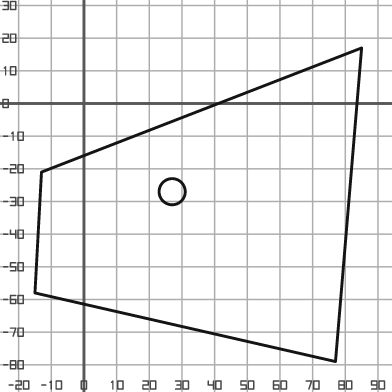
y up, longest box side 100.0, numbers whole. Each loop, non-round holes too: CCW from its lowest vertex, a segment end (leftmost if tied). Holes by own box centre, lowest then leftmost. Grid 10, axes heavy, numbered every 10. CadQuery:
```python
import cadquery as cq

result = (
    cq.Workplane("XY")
    .moveTo(77.0, -79.0)
    .lineTo(85.0, 17.0)
    .lineTo(-13.0, -21.0)
    .lineTo(-15.0, -58.0)
    .close()
    .moveTo(27.0, -27.0)
    .circle(4.0)
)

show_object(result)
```